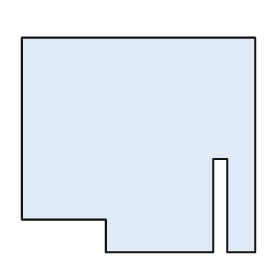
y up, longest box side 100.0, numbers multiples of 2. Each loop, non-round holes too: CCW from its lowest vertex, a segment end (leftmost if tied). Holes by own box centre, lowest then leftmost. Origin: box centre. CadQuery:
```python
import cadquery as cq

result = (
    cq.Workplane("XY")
    .moveTo(-14.0, -46.0)
    .lineTo(32.0, -46.0)
    .lineTo(32.0, -6.0)
    .lineTo(38.0, -6.0)
    .lineTo(38.0, -46.0)
    .lineTo(50.0, -46.0)
    .lineTo(50.0, 46.0)
    .lineTo(-50.0, 46.0)
    .lineTo(-50.0, -32.0)
    .lineTo(-14.0, -32.0)
    .close()
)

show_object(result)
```